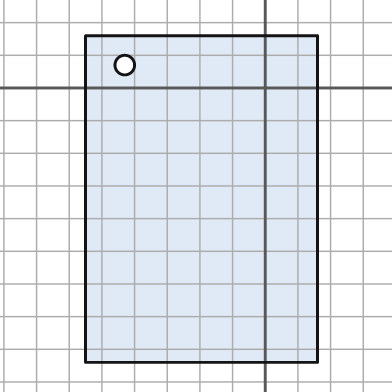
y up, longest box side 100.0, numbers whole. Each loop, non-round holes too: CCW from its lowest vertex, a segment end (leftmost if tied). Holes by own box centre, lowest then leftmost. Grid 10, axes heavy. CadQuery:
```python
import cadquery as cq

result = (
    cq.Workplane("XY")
    .moveTo(-55.0, -84.0)
    .lineTo(16.0, -84.0)
    .lineTo(16.0, 16.0)
    .lineTo(-55.0, 16.0)
    .close()
    .moveTo(-43.0, 7.0)
    .circle(3.0)
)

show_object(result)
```